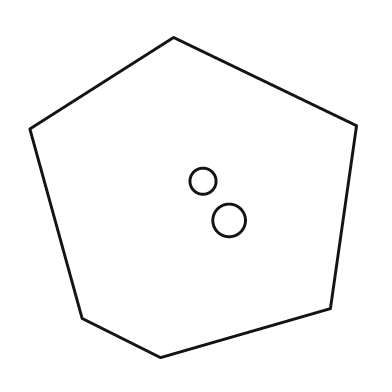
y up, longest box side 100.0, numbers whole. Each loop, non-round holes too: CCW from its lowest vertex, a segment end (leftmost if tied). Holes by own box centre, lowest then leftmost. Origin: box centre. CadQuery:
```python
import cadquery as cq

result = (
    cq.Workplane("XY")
    .moveTo(-10.0, -49.0)
    .lineTo(42.0, -34.0)
    .lineTo(50.0, 22.0)
    .lineTo(-6.0, 49.0)
    .lineTo(-50.0, 21.0)
    .lineTo(-34.0, -37.0)
    .close()
    .moveTo(11.0, -7.0)
    .circle(5.0)
    .moveTo(3.0, 5.0)
    .circle(4.0)
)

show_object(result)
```